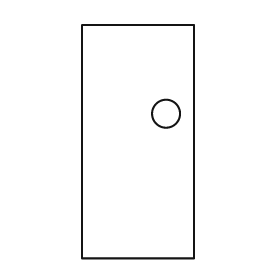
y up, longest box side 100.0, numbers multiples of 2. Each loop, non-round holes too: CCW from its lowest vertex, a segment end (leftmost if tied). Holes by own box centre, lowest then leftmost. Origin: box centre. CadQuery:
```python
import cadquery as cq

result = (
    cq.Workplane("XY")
    .moveTo(-24.0, -50.0)
    .lineTo(24.0, -50.0)
    .lineTo(24.0, 50.0)
    .lineTo(-24.0, 50.0)
    .close()
    .moveTo(12.0, 12.0)
    .circle(6.0)
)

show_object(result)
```